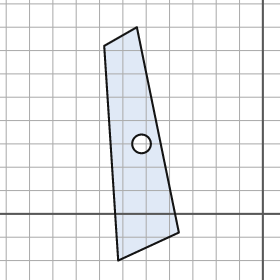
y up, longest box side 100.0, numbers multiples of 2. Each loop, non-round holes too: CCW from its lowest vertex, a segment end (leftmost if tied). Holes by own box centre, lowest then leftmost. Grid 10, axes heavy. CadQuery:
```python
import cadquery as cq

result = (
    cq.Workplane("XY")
    .moveTo(-62.0, -20.0)
    .lineTo(-36.0, -8.0)
    .lineTo(-54.0, 80.0)
    .lineTo(-68.0, 72.0)
    .close()
    .moveTo(-52.0, 30.0)
    .circle(4.0)
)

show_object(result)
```